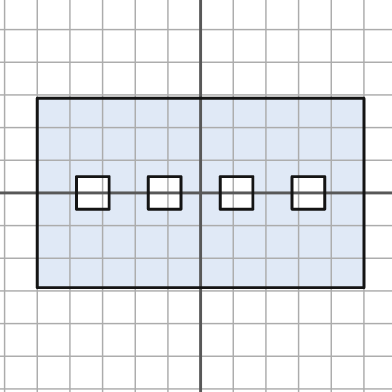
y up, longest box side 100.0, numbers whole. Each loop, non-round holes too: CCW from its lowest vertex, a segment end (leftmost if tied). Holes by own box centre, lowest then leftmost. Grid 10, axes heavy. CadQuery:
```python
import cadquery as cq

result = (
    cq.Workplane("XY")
    .moveTo(-50.0, -29.0)
    .lineTo(50.0, -29.0)
    .lineTo(50.0, 29.0)
    .lineTo(-50.0, 29.0)
    .close()
    .moveTo(-38.0, -5.0)
    .lineTo(-28.0, -5.0)
    .lineTo(-28.0, 5.0)
    .lineTo(-38.0, 5.0)
    .close()
    .moveTo(-16.0, -5.0)
    .lineTo(-6.0, -5.0)
    .lineTo(-6.0, 5.0)
    .lineTo(-16.0, 5.0)
    .close()
    .moveTo(6.0, -5.0)
    .lineTo(16.0, -5.0)
    .lineTo(16.0, 5.0)
    .lineTo(6.0, 5.0)
    .close()
    .moveTo(28.0, -5.0)
    .lineTo(38.0, -5.0)
    .lineTo(38.0, 5.0)
    .lineTo(28.0, 5.0)
    .close()
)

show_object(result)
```